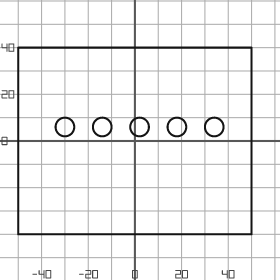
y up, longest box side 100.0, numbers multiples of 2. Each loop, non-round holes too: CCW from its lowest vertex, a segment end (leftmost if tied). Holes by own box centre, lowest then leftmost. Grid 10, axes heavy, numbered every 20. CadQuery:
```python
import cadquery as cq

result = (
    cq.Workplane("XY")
    .moveTo(-50.0, -40.0)
    .lineTo(50.0, -40.0)
    .lineTo(50.0, 40.0)
    .lineTo(-50.0, 40.0)
    .close()
    .moveTo(-30.0, 6.0)
    .circle(4.0)
    .moveTo(-14.0, 6.0)
    .circle(4.0)
    .moveTo(2.0, 6.0)
    .circle(4.0)
    .moveTo(18.0, 6.0)
    .circle(4.0)
    .moveTo(34.0, 6.0)
    .circle(4.0)
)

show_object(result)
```